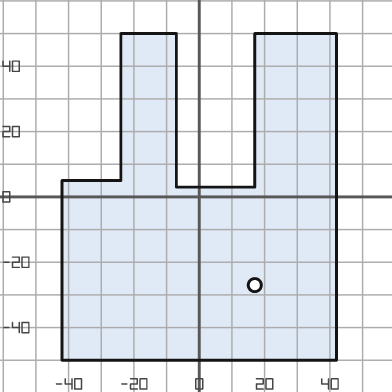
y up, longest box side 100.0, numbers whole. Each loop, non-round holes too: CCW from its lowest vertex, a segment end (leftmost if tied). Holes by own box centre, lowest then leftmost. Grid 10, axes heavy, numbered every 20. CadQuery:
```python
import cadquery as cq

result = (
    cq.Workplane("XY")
    .moveTo(-42.0, -50.0)
    .lineTo(42.0, -50.0)
    .lineTo(42.0, 50.0)
    .lineTo(17.0, 50.0)
    .lineTo(17.0, 3.0)
    .lineTo(-7.0, 3.0)
    .lineTo(-7.0, 50.0)
    .lineTo(-24.0, 50.0)
    .lineTo(-24.0, 5.0)
    .lineTo(-42.0, 5.0)
    .close()
    .moveTo(17.0, -27.0)
    .circle(2.0)
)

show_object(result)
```